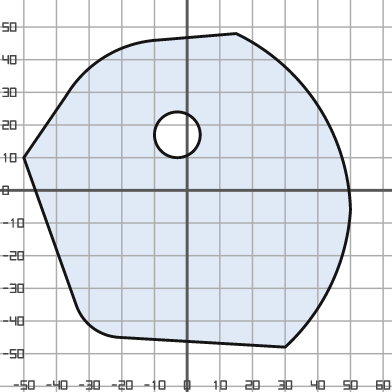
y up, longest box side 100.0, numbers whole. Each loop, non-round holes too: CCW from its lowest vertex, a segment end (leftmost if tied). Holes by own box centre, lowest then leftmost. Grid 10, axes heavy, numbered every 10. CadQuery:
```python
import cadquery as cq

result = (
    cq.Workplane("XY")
    .moveTo(30.0, -48.0)
    .threePointArc((44.0, -29.0), (50.0, -6.0))
    .threePointArc((40.0, 26.0), (15.0, 48.0))
    .lineTo(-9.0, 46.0)
    .threePointArc((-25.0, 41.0), (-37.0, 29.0))
    .lineTo(-50.0, 10.0)
    .lineTo(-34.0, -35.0)
    .threePointArc((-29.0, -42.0), (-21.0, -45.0))
    .close()
    .moveTo(-3.0, 17.0)
    .circle(7.0)
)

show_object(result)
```